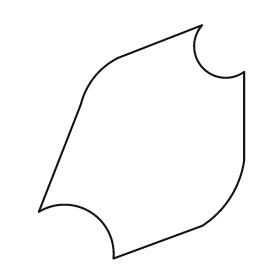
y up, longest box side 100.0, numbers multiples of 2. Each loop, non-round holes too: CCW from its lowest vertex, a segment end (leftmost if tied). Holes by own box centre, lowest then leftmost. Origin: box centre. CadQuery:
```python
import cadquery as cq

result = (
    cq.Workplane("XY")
    .moveTo(-12.0, -50.0)
    .lineTo(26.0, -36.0)
    .threePointArc((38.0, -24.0), (44.0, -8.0))
    .lineTo(44.0, 30.0)
    .threePointArc((26.0, 32.0), (26.0, 50.0))
    .lineTo(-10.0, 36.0)
    .threePointArc((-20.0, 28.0), (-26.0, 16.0))
    .lineTo(-44.0, -30.0)
    .threePointArc((-22.0, -30.0), (-12.0, -50.0))
    .close()
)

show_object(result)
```